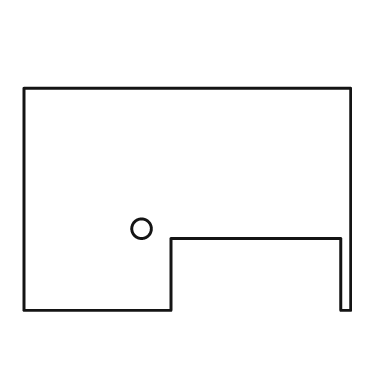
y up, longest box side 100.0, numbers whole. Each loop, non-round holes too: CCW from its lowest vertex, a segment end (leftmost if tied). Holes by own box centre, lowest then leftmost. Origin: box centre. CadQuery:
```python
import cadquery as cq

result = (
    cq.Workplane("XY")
    .moveTo(-50.0, -34.0)
    .lineTo(-5.0, -34.0)
    .lineTo(-5.0, -12.0)
    .lineTo(47.0, -12.0)
    .lineTo(47.0, -34.0)
    .lineTo(50.0, -34.0)
    .lineTo(50.0, 34.0)
    .lineTo(-50.0, 34.0)
    .close()
    .moveTo(-14.0, -9.0)
    .circle(3.0)
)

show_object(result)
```